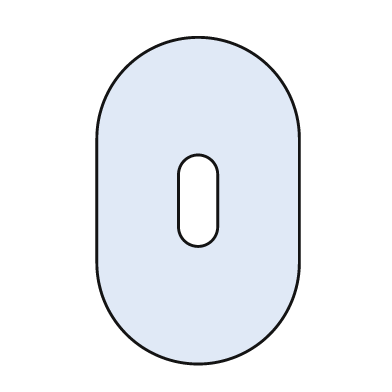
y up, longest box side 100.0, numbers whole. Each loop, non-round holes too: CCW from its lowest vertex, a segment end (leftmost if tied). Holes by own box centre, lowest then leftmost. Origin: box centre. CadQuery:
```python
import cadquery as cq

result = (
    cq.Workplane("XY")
    .moveTo(-31.0, -19.0)
    .threePointArc((0.0, -50.0), (31.0, -19.0))
    .lineTo(31.0, 19.0)
    .threePointArc((0.0, 50.0), (-31.0, 19.0))
    .close()
    .moveTo(-6.0, -8.0)
    .threePointArc((0.0, -14.0), (6.0, -8.0))
    .lineTo(6.0, 8.0)
    .threePointArc((0.0, 14.0), (-6.0, 8.0))
    .close()
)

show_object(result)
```